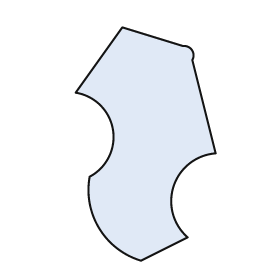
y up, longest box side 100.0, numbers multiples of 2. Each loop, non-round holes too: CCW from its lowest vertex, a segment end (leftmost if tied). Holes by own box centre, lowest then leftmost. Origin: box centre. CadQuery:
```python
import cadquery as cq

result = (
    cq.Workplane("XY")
    .moveTo(-2.0, -50.0)
    .lineTo(18.0, -40.0)
    .threePointArc((12.0, -18.0), (30.0, -4.0))
    .lineTo(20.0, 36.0)
    .threePointArc((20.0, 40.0), (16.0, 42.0))
    .lineTo(-10.0, 50.0)
    .lineTo(-30.0, 22.0)
    .threePointArc((-14.0, 6.0), (-24.0, -14.0))
    .threePointArc((-20.0, -36.0), (-2.0, -50.0))
    .close()
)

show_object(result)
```